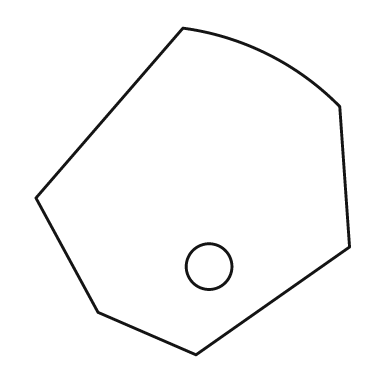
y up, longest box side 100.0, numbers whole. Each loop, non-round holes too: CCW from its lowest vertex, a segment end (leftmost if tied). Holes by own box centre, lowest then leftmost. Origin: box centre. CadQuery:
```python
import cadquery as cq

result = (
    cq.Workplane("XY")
    .moveTo(1.0, -50.0)
    .lineTo(48.0, -17.0)
    .lineTo(45.0, 26.0)
    .threePointArc((23.0, 42.0), (-3.0, 50.0))
    .lineTo(-48.0, -2.0)
    .lineTo(-29.0, -37.0)
    .close()
    .moveTo(5.0, -23.0)
    .circle(7.0)
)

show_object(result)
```